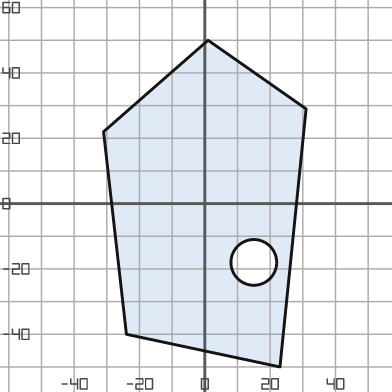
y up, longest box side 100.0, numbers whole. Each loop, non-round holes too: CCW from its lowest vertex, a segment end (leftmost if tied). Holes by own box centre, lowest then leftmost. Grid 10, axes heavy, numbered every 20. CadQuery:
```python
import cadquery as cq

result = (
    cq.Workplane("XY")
    .moveTo(23.0, -50.0)
    .lineTo(31.0, 29.0)
    .lineTo(1.0, 50.0)
    .lineTo(-31.0, 22.0)
    .lineTo(-24.0, -40.0)
    .close()
    .moveTo(15.0, -18.0)
    .circle(7.0)
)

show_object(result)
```